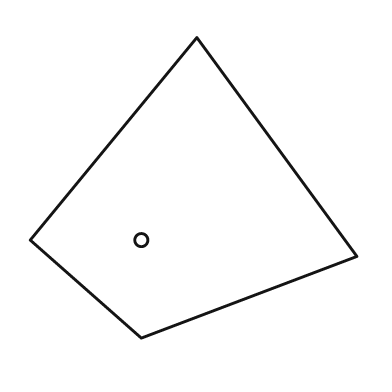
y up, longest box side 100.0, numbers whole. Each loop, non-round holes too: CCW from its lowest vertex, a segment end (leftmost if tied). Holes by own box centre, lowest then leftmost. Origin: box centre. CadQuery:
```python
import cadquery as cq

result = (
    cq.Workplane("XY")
    .moveTo(-16.0, -46.0)
    .lineTo(50.0, -21.0)
    .lineTo(1.0, 46.0)
    .lineTo(-50.0, -16.0)
    .close()
    .moveTo(-16.0, -16.0)
    .circle(2.0)
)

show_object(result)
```